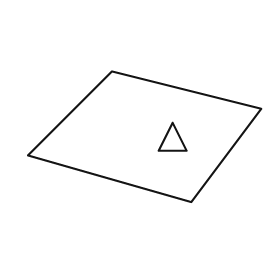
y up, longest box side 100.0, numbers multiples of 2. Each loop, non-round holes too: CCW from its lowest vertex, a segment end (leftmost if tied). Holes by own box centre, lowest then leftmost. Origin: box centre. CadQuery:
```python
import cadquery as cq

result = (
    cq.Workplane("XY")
    .moveTo(20.0, -28.0)
    .lineTo(50.0, 12.0)
    .lineTo(-14.0, 28.0)
    .lineTo(-50.0, -8.0)
    .close()
    .moveTo(6.0, -6.0)
    .lineTo(18.0, -6.0)
    .lineTo(12.0, 6.0)
    .close()
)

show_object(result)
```